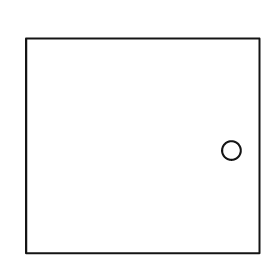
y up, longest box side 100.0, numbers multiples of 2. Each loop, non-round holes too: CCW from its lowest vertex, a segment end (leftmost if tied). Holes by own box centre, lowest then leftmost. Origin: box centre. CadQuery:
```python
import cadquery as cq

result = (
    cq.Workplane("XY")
    .moveTo(-50.0, -46.0)
    .lineTo(50.0, -46.0)
    .lineTo(50.0, 46.0)
    .lineTo(-50.0, 46.0)
    .close()
    .moveTo(38.0, -2.0)
    .circle(4.0)
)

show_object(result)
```